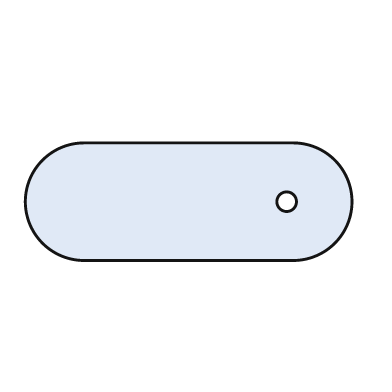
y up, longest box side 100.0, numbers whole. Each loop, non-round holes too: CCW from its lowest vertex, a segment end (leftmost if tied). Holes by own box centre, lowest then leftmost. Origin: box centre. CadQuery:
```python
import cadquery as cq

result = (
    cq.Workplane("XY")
    .moveTo(-32.0, -18.0)
    .lineTo(32.0, -18.0)
    .threePointArc((50.0, 0.0), (32.0, 18.0))
    .lineTo(-32.0, 18.0)
    .threePointArc((-50.0, 0.0), (-32.0, -18.0))
    .close()
    .moveTo(30.0, 0.0)
    .circle(3.0)
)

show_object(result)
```